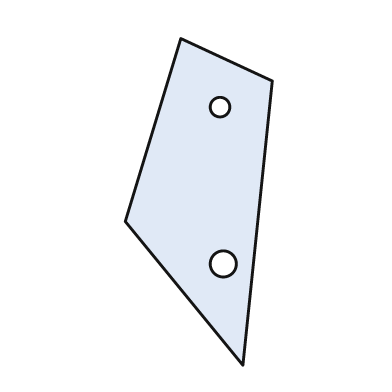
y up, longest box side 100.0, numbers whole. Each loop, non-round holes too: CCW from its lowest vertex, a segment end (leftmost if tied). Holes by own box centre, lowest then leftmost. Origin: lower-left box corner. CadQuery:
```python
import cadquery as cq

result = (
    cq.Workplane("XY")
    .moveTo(36.0, 0.0)
    .lineTo(45.0, 87.0)
    .lineTo(17.0, 100.0)
    .lineTo(0.0, 44.0)
    .close()
    .moveTo(30.0, 31.0)
    .circle(4.0)
    .moveTo(29.0, 79.0)
    .circle(3.0)
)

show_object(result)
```